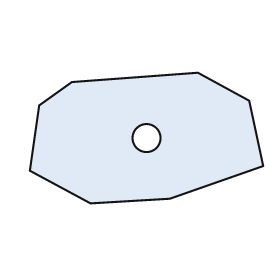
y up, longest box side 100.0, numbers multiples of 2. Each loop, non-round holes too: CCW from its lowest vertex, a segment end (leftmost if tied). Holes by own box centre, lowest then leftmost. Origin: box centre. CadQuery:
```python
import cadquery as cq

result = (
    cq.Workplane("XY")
    .moveTo(-24.0, -28.0)
    .lineTo(10.0, -26.0)
    .lineTo(50.0, -12.0)
    .lineTo(44.0, 16.0)
    .lineTo(22.0, 28.0)
    .lineTo(-32.0, 24.0)
    .lineTo(-46.0, 14.0)
    .lineTo(-50.0, -14.0)
    .close()
    .moveTo(0.0, 0.0)
    .circle(6.0)
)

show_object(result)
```